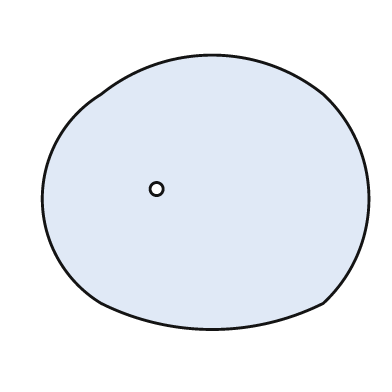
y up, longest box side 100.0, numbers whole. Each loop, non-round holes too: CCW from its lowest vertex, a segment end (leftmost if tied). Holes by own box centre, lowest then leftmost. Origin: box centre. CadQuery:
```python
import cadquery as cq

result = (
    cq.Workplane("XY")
    .moveTo(-32.0, -34.0)
    .threePointArc((2.0, -42.0), (36.0, -34.0))
    .threePointArc((50.0, -2.0), (36.0, 30.0))
    .threePointArc((2.0, 42.0), (-32.0, 30.0))
    .threePointArc((-50.0, -2.0), (-32.0, -34.0))
    .close()
    .moveTo(-15.0, 1.0)
    .circle(2.0)
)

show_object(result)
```